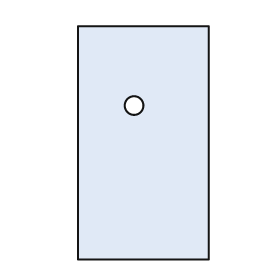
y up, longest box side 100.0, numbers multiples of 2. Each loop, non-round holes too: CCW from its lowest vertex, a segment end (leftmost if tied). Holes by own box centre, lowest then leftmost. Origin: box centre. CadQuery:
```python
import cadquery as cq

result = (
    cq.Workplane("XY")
    .moveTo(-28.0, -50.0)
    .lineTo(28.0, -50.0)
    .lineTo(28.0, 50.0)
    .lineTo(-28.0, 50.0)
    .close()
    .moveTo(-4.0, 16.0)
    .circle(4.0)
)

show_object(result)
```